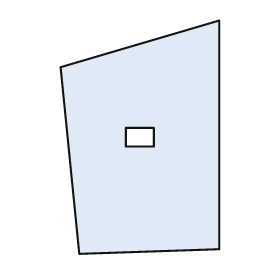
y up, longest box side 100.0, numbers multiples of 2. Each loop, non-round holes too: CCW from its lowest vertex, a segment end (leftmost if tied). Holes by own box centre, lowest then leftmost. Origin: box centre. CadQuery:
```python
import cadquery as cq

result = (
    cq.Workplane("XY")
    .moveTo(-26.0, -50.0)
    .lineTo(34.0, -48.0)
    .lineTo(34.0, 50.0)
    .lineTo(-34.0, 30.0)
    .close()
    .moveTo(-6.0, -4.0)
    .lineTo(6.0, -4.0)
    .lineTo(6.0, 4.0)
    .lineTo(-6.0, 4.0)
    .close()
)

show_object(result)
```